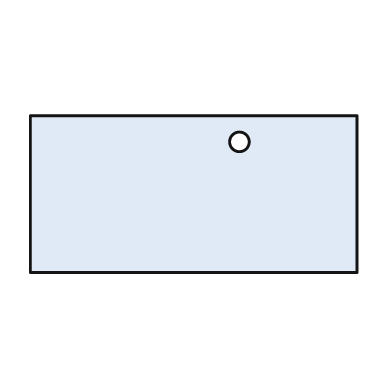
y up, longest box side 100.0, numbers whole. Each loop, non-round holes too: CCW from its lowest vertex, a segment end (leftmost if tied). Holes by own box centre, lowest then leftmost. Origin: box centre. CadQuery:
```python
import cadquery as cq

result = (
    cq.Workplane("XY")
    .moveTo(-50.0, -24.0)
    .lineTo(50.0, -24.0)
    .lineTo(50.0, 24.0)
    .lineTo(-50.0, 24.0)
    .close()
    .moveTo(14.0, 16.0)
    .circle(3.0)
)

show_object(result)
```